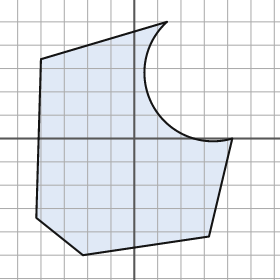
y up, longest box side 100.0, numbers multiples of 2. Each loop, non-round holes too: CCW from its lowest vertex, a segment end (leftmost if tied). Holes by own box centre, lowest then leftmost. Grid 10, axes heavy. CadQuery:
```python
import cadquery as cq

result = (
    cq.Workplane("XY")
    .moveTo(-22.0, -50.0)
    .lineTo(32.0, -42.0)
    .lineTo(42.0, 0.0)
    .threePointArc((8.0, 14.0), (14.0, 50.0))
    .lineTo(-40.0, 34.0)
    .lineTo(-42.0, -34.0)
    .close()
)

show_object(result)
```